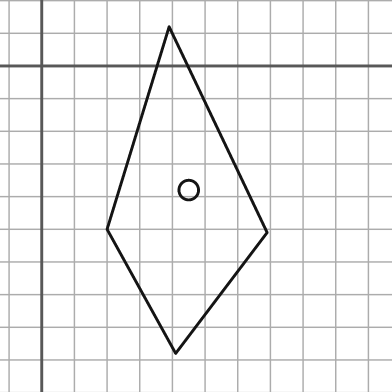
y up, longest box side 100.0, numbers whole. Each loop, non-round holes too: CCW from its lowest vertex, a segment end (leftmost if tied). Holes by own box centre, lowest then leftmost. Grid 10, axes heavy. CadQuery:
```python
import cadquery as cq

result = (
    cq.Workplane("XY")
    .moveTo(41.0, -88.0)
    .lineTo(69.0, -51.0)
    .lineTo(39.0, 12.0)
    .lineTo(20.0, -50.0)
    .close()
    .moveTo(45.0, -38.0)
    .circle(3.0)
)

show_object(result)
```